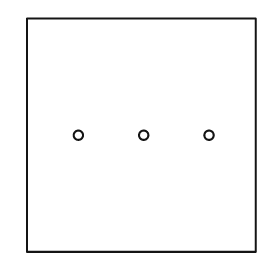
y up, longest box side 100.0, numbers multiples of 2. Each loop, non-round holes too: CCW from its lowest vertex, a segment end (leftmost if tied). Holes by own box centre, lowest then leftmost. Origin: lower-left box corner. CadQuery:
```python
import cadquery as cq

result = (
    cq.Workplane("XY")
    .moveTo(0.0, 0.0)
    .lineTo(98.0, 0.0)
    .lineTo(98.0, 100.0)
    .lineTo(0.0, 100.0)
    .close()
    .moveTo(22.0, 50.0)
    .circle(2.0)
    .moveTo(50.0, 50.0)
    .circle(2.0)
    .moveTo(78.0, 50.0)
    .circle(2.0)
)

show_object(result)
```